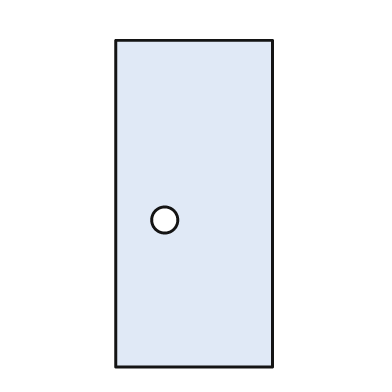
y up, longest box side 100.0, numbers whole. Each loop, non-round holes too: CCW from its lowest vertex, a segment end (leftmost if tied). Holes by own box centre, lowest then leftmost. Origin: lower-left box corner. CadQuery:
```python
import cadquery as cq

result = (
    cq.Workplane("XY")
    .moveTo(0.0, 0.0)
    .lineTo(48.0, 0.0)
    .lineTo(48.0, 100.0)
    .lineTo(0.0, 100.0)
    .close()
    .moveTo(15.0, 45.0)
    .circle(4.0)
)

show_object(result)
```